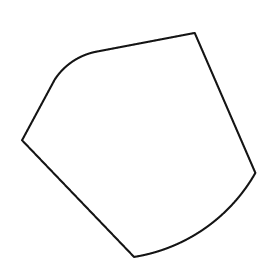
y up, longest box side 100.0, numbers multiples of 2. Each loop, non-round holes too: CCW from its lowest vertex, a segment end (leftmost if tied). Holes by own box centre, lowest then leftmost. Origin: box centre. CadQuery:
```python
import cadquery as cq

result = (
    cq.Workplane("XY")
    .moveTo(-2.0, -48.0)
    .threePointArc((28.0, -36.0), (50.0, -12.0))
    .lineTo(24.0, 48.0)
    .lineTo(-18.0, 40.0)
    .threePointArc((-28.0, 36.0), (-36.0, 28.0))
    .lineTo(-50.0, 2.0)
    .close()
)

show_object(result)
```